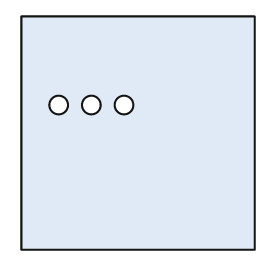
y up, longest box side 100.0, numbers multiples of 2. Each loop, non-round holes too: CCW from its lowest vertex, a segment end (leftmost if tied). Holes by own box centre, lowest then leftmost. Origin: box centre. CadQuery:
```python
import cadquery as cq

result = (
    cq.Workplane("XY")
    .moveTo(-50.0, -50.0)
    .lineTo(50.0, -50.0)
    .lineTo(50.0, 50.0)
    .lineTo(-50.0, 50.0)
    .close()
    .moveTo(-34.0, 12.0)
    .circle(4.0)
    .moveTo(-20.0, 12.0)
    .circle(4.0)
    .moveTo(-6.0, 12.0)
    .circle(4.0)
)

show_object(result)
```